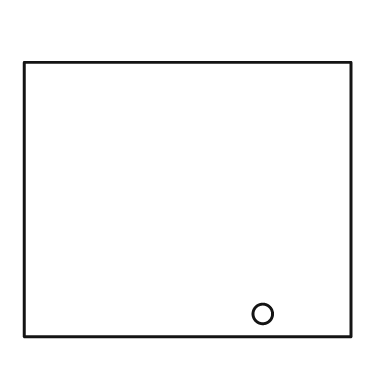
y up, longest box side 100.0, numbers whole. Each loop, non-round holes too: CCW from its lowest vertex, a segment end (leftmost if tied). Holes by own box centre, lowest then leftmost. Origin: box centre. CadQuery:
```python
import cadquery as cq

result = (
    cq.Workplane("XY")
    .moveTo(-50.0, -42.0)
    .lineTo(50.0, -42.0)
    .lineTo(50.0, 42.0)
    .lineTo(-50.0, 42.0)
    .close()
    .moveTo(23.0, -35.0)
    .circle(3.0)
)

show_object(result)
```